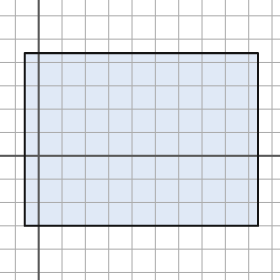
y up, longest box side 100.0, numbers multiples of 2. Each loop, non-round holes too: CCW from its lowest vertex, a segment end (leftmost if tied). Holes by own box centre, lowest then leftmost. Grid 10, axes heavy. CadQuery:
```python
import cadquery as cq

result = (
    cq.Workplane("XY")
    .moveTo(-6.0, -30.0)
    .lineTo(94.0, -30.0)
    .lineTo(94.0, 44.0)
    .lineTo(-6.0, 44.0)
    .close()
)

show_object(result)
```